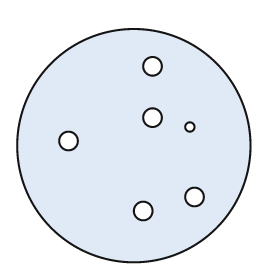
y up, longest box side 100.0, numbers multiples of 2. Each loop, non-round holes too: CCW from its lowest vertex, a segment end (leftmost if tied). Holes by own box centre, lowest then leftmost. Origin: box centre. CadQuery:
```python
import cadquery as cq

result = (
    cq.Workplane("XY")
    .moveTo(0.0, 0.0)
    .circle(50.0)
    .moveTo(4.0, -28.0)
    .circle(4.0)
    .moveTo(26.0, -22.0)
    .circle(4.0)
    .moveTo(-28.0, 2.0)
    .circle(4.0)
    .moveTo(24.0, 8.0)
    .circle(2.0)
    .moveTo(8.0, 12.0)
    .circle(4.0)
    .moveTo(8.0, 34.0)
    .circle(4.0)
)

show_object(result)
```